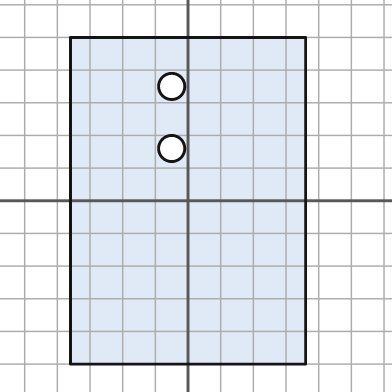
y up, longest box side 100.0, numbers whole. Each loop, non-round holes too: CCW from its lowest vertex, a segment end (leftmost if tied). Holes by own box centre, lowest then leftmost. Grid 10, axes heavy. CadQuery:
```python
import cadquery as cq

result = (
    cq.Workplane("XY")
    .moveTo(-36.0, -50.0)
    .lineTo(36.0, -50.0)
    .lineTo(36.0, 50.0)
    .lineTo(-36.0, 50.0)
    .close()
    .moveTo(-5.0, 16.0)
    .circle(4.0)
    .moveTo(-5.0, 35.0)
    .circle(4.0)
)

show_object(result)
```